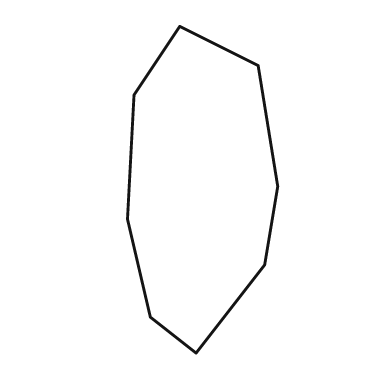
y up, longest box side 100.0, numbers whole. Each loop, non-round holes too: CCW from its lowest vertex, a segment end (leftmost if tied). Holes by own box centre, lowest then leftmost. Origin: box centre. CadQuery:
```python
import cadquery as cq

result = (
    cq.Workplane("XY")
    .moveTo(-2.0, -50.0)
    .lineTo(19.0, -23.0)
    .lineTo(23.0, 1.0)
    .lineTo(17.0, 38.0)
    .lineTo(-7.0, 50.0)
    .lineTo(-21.0, 29.0)
    .lineTo(-23.0, -9.0)
    .lineTo(-16.0, -39.0)
    .close()
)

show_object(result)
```